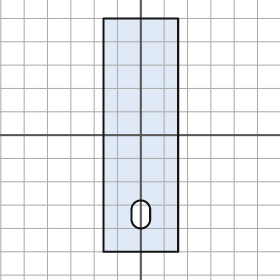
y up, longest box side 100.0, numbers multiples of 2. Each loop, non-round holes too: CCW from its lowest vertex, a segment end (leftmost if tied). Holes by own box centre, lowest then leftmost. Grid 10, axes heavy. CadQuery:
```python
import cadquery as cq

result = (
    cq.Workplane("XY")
    .moveTo(-16.0, -50.0)
    .lineTo(16.0, -50.0)
    .lineTo(16.0, 50.0)
    .lineTo(-16.0, 50.0)
    .close()
    .moveTo(-4.0, -36.0)
    .threePointArc((0.0, -40.0), (4.0, -36.0))
    .lineTo(4.0, -32.0)
    .threePointArc((0.0, -28.0), (-4.0, -32.0))
    .close()
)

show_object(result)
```